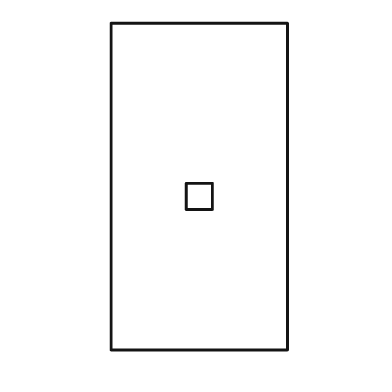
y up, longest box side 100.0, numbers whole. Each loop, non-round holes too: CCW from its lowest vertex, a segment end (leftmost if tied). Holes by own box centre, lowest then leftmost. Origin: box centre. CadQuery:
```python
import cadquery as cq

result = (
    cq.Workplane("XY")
    .moveTo(-27.0, -50.0)
    .lineTo(27.0, -50.0)
    .lineTo(27.0, 50.0)
    .lineTo(-27.0, 50.0)
    .close()
    .moveTo(-4.0, -7.0)
    .lineTo(4.0, -7.0)
    .lineTo(4.0, 1.0)
    .lineTo(-4.0, 1.0)
    .close()
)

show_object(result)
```